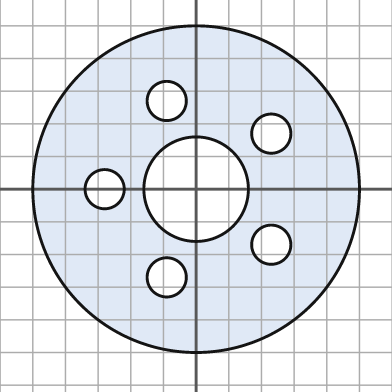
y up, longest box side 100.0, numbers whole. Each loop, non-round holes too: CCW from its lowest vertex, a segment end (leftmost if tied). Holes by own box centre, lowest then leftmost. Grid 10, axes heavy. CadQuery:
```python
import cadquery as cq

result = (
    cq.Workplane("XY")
    .moveTo(0.0, 0.0)
    .circle(50.0)
    .moveTo(-9.0, -27.0)
    .circle(6.0)
    .moveTo(23.0, -17.0)
    .circle(6.0)
    .moveTo(-28.0, 0.0)
    .circle(6.0)
    .moveTo(0.0, 0.0)
    .circle(16.0)
    .moveTo(23.0, 17.0)
    .circle(6.0)
    .moveTo(-9.0, 27.0)
    .circle(6.0)
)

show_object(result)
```